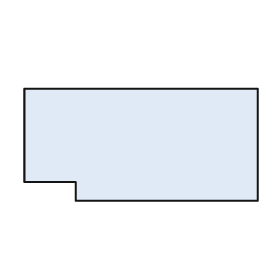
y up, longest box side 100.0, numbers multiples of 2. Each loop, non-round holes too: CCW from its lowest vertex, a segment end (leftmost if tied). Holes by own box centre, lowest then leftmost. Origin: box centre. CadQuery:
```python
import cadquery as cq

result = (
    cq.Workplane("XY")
    .moveTo(-28.0, -24.0)
    .lineTo(50.0, -24.0)
    .lineTo(50.0, 24.0)
    .lineTo(-50.0, 24.0)
    .lineTo(-50.0, -16.0)
    .lineTo(-28.0, -16.0)
    .close()
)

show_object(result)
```